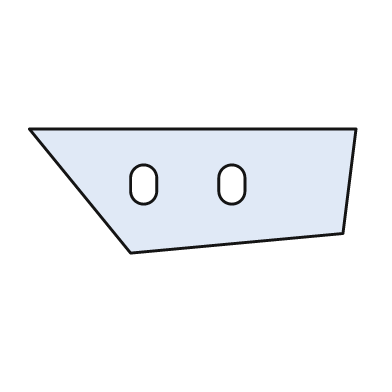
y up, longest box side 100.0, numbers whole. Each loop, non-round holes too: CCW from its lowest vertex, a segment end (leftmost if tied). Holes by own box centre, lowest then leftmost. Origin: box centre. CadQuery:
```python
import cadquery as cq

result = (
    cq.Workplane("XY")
    .moveTo(-19.0, -19.0)
    .lineTo(46.0, -13.0)
    .lineTo(50.0, 19.0)
    .lineTo(-50.0, 19.0)
    .close()
    .moveTo(-19.0, 0.0)
    .threePointArc((-15.0, -4.0), (-11.0, 0.0))
    .lineTo(-11.0, 4.0)
    .threePointArc((-15.0, 8.0), (-19.0, 4.0))
    .close()
    .moveTo(8.0, 0.0)
    .threePointArc((12.0, -4.0), (16.0, 0.0))
    .lineTo(16.0, 4.0)
    .threePointArc((12.0, 8.0), (8.0, 4.0))
    .close()
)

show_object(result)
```